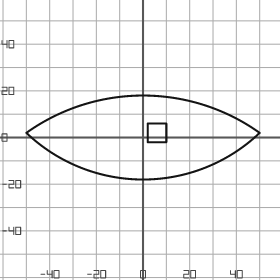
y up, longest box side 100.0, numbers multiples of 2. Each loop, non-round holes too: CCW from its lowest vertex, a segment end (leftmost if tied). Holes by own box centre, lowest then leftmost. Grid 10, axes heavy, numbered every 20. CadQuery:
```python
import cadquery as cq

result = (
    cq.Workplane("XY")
    .moveTo(-50.0, 2.0)
    .threePointArc((0.0, -18.0), (50.0, 2.0))
    .threePointArc((0.0, 18.0), (-50.0, 2.0))
    .close()
    .moveTo(2.0, -2.0)
    .lineTo(10.0, -2.0)
    .lineTo(10.0, 6.0)
    .lineTo(2.0, 6.0)
    .close()
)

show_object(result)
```